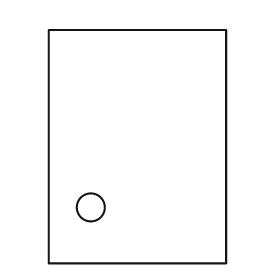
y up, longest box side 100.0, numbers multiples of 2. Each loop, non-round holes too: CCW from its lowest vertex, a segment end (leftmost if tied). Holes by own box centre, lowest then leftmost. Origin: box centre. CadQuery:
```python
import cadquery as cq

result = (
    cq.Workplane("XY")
    .moveTo(-38.0, -50.0)
    .lineTo(38.0, -50.0)
    .lineTo(38.0, 50.0)
    .lineTo(-38.0, 50.0)
    .close()
    .moveTo(-20.0, -26.0)
    .circle(6.0)
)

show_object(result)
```